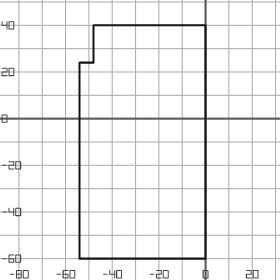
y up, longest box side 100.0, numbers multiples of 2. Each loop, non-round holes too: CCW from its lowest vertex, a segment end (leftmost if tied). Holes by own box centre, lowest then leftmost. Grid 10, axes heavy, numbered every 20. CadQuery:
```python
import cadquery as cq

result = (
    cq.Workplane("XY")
    .moveTo(-54.0, -60.0)
    .lineTo(0.0, -60.0)
    .lineTo(0.0, 40.0)
    .lineTo(-48.0, 40.0)
    .lineTo(-48.0, 24.0)
    .lineTo(-54.0, 24.0)
    .close()
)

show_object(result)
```